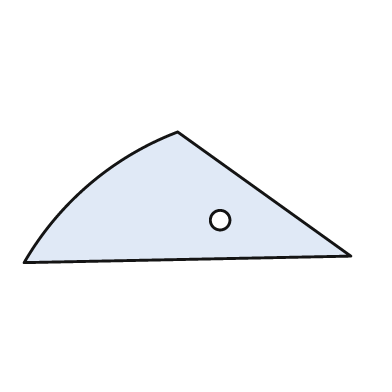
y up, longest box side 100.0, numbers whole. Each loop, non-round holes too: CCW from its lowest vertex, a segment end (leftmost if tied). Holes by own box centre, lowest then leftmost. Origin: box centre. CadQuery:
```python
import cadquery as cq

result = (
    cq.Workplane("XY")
    .moveTo(-50.0, -20.0)
    .lineTo(50.0, -18.0)
    .lineTo(-3.0, 20.0)
    .threePointArc((-30.0, 4.0), (-50.0, -20.0))
    .close()
    .moveTo(10.0, -7.0)
    .circle(3.0)
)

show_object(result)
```